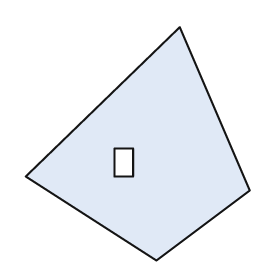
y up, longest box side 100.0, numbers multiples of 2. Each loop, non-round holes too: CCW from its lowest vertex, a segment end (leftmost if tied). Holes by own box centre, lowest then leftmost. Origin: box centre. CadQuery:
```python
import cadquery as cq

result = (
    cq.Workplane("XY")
    .moveTo(8.0, -50.0)
    .lineTo(48.0, -20.0)
    .lineTo(18.0, 50.0)
    .lineTo(-48.0, -14.0)
    .close()
    .moveTo(-10.0, -14.0)
    .lineTo(-2.0, -14.0)
    .lineTo(-2.0, -2.0)
    .lineTo(-10.0, -2.0)
    .close()
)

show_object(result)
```